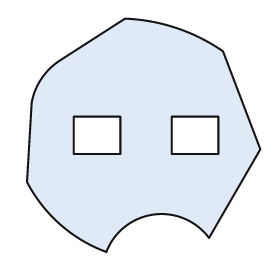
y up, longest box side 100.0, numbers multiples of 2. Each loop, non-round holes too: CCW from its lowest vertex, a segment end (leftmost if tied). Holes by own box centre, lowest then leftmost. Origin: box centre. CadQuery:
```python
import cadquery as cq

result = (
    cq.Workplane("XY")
    .moveTo(-16.0, -50.0)
    .threePointArc((4.0, -34.0), (28.0, -44.0))
    .lineTo(50.0, -6.0)
    .lineTo(34.0, 36.0)
    .threePointArc((14.0, 46.0), (-8.0, 50.0))
    .lineTo(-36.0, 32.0)
    .threePointArc((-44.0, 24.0), (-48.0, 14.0))
    .lineTo(-50.0, -20.0)
    .threePointArc((-36.0, -38.0), (-16.0, -50.0))
    .close()
    .moveTo(-30.0, -8.0)
    .lineTo(-10.0, -8.0)
    .lineTo(-10.0, 8.0)
    .lineTo(-30.0, 8.0)
    .close()
    .moveTo(12.0, -8.0)
    .lineTo(32.0, -8.0)
    .lineTo(32.0, 8.0)
    .lineTo(12.0, 8.0)
    .close()
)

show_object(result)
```